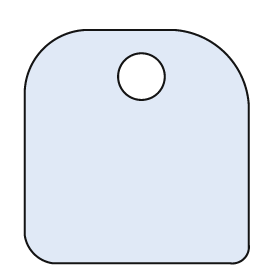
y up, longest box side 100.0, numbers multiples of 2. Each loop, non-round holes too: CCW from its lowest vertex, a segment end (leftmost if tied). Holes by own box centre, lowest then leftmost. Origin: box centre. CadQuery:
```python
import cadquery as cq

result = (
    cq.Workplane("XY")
    .moveTo(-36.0, -50.0)
    .lineTo(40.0, -50.0)
    .threePointArc((46.0, -48.0), (48.0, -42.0))
    .lineTo(48.0, 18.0)
    .threePointArc((38.0, 40.0), (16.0, 50.0))
    .lineTo(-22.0, 50.0)
    .threePointArc((-40.0, 42.0), (-48.0, 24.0))
    .lineTo(-48.0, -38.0)
    .threePointArc((-44.0, -46.0), (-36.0, -50.0))
    .close()
    .moveTo(2.0, 30.0)
    .circle(10.0)
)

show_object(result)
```